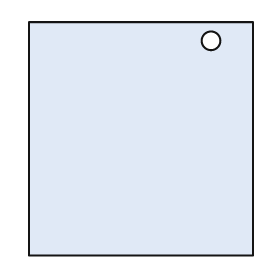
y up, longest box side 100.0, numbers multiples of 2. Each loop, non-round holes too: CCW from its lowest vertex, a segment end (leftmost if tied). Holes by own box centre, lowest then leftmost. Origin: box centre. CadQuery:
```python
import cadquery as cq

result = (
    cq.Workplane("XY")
    .moveTo(-48.0, -50.0)
    .lineTo(48.0, -50.0)
    .lineTo(48.0, 50.0)
    .lineTo(-48.0, 50.0)
    .close()
    .moveTo(30.0, 42.0)
    .circle(4.0)
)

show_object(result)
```